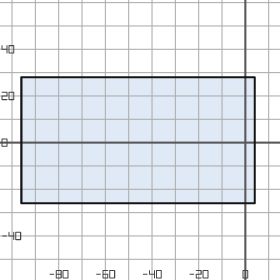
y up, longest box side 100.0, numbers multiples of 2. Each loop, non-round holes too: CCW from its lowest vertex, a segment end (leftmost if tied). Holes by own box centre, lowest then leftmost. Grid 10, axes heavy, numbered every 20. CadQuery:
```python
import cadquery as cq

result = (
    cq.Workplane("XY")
    .moveTo(-96.0, -26.0)
    .lineTo(4.0, -26.0)
    .lineTo(4.0, 28.0)
    .lineTo(-96.0, 28.0)
    .close()
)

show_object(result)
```